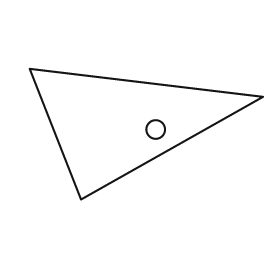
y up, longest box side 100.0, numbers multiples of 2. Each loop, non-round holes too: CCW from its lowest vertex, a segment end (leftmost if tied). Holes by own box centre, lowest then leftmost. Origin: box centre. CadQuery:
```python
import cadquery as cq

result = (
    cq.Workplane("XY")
    .moveTo(-28.0, -28.0)
    .lineTo(50.0, 16.0)
    .lineTo(-50.0, 28.0)
    .close()
    .moveTo(4.0, 2.0)
    .circle(4.0)
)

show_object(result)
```